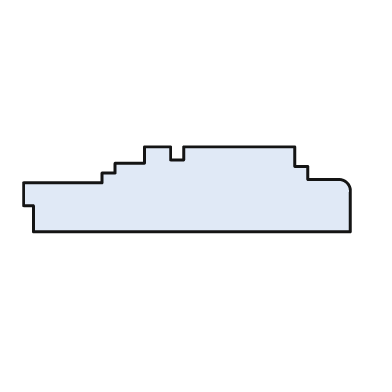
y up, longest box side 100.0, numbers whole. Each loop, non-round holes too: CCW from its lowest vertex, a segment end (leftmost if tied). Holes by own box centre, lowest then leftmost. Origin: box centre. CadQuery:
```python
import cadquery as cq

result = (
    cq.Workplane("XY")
    .moveTo(-47.0, -13.0)
    .lineTo(50.0, -13.0)
    .lineTo(50.0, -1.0)
    .threePointArc((49.0, 2.0), (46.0, 3.0))
    .lineTo(37.0, 3.0)
    .lineTo(37.0, 7.0)
    .lineTo(33.0, 7.0)
    .lineTo(33.0, 13.0)
    .lineTo(-1.0, 13.0)
    .lineTo(-1.0, 9.0)
    .lineTo(-5.0, 9.0)
    .lineTo(-5.0, 13.0)
    .lineTo(-13.0, 13.0)
    .lineTo(-13.0, 8.0)
    .lineTo(-22.0, 8.0)
    .lineTo(-22.0, 5.0)
    .lineTo(-26.0, 5.0)
    .lineTo(-26.0, 2.0)
    .lineTo(-50.0, 2.0)
    .lineTo(-50.0, -5.0)
    .lineTo(-47.0, -5.0)
    .close()
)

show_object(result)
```